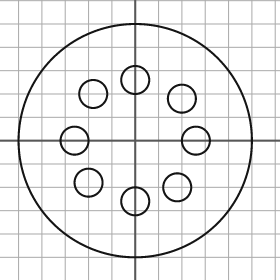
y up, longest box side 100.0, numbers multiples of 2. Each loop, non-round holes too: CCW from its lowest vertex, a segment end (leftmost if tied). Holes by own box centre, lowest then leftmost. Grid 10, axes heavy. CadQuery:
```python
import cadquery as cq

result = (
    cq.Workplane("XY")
    .moveTo(0.0, 0.0)
    .circle(50.0)
    .moveTo(0.0, -26.0)
    .circle(6.0)
    .moveTo(18.0, -20.0)
    .circle(6.0)
    .moveTo(-20.0, -18.0)
    .circle(6.0)
    .moveTo(-26.0, 0.0)
    .circle(6.0)
    .moveTo(26.0, 0.0)
    .circle(6.0)
    .moveTo(20.0, 18.0)
    .circle(6.0)
    .moveTo(-18.0, 20.0)
    .circle(6.0)
    .moveTo(0.0, 26.0)
    .circle(6.0)
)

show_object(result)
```